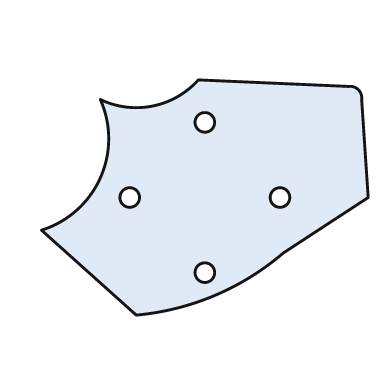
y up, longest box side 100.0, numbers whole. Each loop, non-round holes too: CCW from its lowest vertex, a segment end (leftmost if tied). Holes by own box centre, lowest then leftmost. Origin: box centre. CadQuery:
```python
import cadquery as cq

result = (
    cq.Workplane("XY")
    .moveTo(-21.0, -36.0)
    .threePointArc((3.0, -30.0), (24.0, -17.0))
    .lineTo(50.0, 0.0)
    .lineTo(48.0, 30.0)
    .threePointArc((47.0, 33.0), (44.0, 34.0))
    .lineTo(-2.0, 36.0)
    .threePointArc((-16.0, 28.0), (-32.0, 30.0))
    .threePointArc((-32.0, 6.0), (-50.0, -10.0))
    .close()
    .moveTo(0.0, -23.0)
    .circle(3.0)
    .moveTo(-23.0, 0.0)
    .circle(3.0)
    .moveTo(23.0, 0.0)
    .circle(3.0)
    .moveTo(0.0, 23.0)
    .circle(3.0)
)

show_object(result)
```